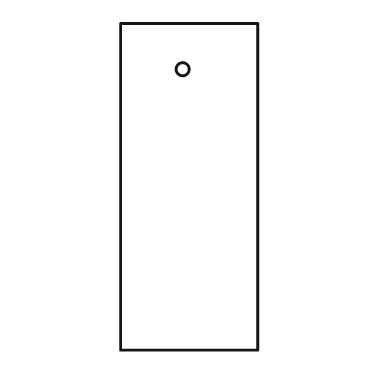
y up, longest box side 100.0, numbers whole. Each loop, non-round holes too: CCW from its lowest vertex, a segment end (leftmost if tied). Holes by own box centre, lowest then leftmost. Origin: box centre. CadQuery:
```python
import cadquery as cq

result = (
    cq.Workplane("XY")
    .moveTo(-21.0, -50.0)
    .lineTo(21.0, -50.0)
    .lineTo(21.0, 50.0)
    .lineTo(-21.0, 50.0)
    .close()
    .moveTo(-2.0, 36.0)
    .circle(2.0)
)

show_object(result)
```